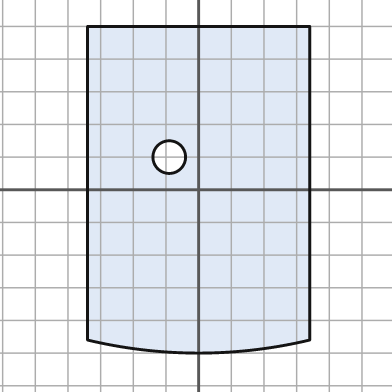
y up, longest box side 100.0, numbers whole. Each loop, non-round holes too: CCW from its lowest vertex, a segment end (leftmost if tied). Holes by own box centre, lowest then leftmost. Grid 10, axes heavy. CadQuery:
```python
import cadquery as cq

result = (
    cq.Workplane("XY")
    .moveTo(-34.0, -46.0)
    .threePointArc((0.0, -50.0), (34.0, -46.0))
    .lineTo(34.0, 50.0)
    .lineTo(-34.0, 50.0)
    .close()
    .moveTo(-9.0, 10.0)
    .circle(5.0)
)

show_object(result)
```